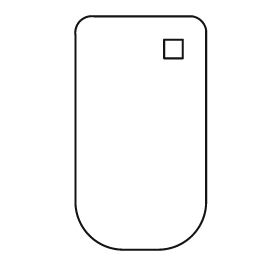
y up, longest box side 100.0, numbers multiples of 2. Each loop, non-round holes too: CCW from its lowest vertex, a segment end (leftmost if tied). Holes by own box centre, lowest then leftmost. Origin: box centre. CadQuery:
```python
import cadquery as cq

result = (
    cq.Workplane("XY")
    .moveTo(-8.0, -50.0)
    .lineTo(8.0, -50.0)
    .threePointArc((22.0, -44.0), (28.0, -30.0))
    .lineTo(28.0, 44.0)
    .threePointArc((26.0, 48.0), (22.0, 50.0))
    .lineTo(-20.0, 50.0)
    .threePointArc((-26.0, 48.0), (-28.0, 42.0))
    .lineTo(-28.0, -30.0)
    .threePointArc((-22.0, -44.0), (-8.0, -50.0))
    .close()
    .moveTo(10.0, 32.0)
    .lineTo(18.0, 32.0)
    .lineTo(18.0, 40.0)
    .lineTo(10.0, 40.0)
    .close()
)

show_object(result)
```